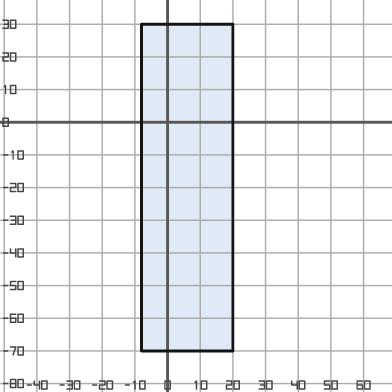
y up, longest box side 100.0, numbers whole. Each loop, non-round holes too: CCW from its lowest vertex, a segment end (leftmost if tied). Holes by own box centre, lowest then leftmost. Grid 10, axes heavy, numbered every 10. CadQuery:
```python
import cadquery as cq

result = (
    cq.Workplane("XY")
    .moveTo(-8.0, -70.0)
    .lineTo(20.0, -70.0)
    .lineTo(20.0, 30.0)
    .lineTo(-8.0, 30.0)
    .close()
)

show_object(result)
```